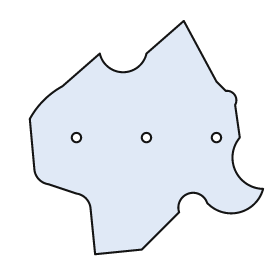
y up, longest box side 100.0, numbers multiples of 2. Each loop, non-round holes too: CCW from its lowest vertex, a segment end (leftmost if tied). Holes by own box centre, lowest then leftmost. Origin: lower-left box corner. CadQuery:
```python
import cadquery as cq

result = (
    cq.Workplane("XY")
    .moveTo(28.0, 0.0)
    .lineTo(48.0, 2.0)
    .lineTo(64.0, 18.0)
    .threePointArc((68.0, 26.0), (76.0, 22.0))
    .threePointArc((90.0, 18.0), (100.0, 28.0))
    .threePointArc((88.0, 36.0), (90.0, 50.0))
    .lineTo(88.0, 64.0)
    .threePointArc((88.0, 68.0), (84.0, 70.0))
    .lineTo(80.0, 74.0)
    .lineTo(66.0, 100.0)
    .lineTo(50.0, 86.0)
    .threePointArc((40.0, 78.0), (30.0, 86.0))
    .lineTo(14.0, 72.0)
    .threePointArc((6.0, 66.0), (0.0, 58.0))
    .lineTo(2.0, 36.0)
    .threePointArc((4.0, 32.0), (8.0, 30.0))
    .lineTo(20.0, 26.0)
    .threePointArc((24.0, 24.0), (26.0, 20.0))
    .close()
    .moveTo(20.0, 50.0)
    .circle(2.0)
    .moveTo(50.0, 50.0)
    .circle(2.0)
    .moveTo(80.0, 50.0)
    .circle(2.0)
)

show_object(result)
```